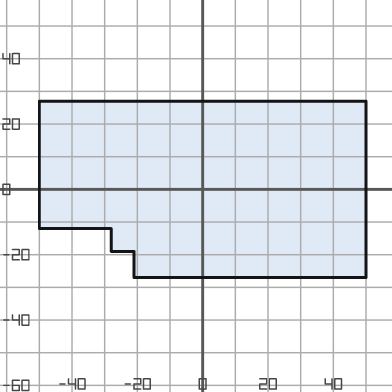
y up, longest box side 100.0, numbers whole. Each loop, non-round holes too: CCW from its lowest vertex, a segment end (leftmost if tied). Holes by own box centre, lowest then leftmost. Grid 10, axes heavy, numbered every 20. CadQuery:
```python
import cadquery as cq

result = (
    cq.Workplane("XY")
    .moveTo(-21.0, -27.0)
    .lineTo(50.0, -27.0)
    .lineTo(50.0, 27.0)
    .lineTo(-50.0, 27.0)
    .lineTo(-50.0, -12.0)
    .lineTo(-28.0, -12.0)
    .lineTo(-28.0, -19.0)
    .lineTo(-21.0, -19.0)
    .close()
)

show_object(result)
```